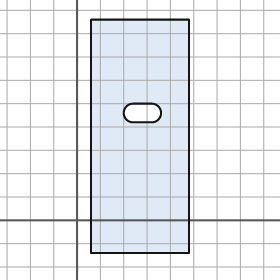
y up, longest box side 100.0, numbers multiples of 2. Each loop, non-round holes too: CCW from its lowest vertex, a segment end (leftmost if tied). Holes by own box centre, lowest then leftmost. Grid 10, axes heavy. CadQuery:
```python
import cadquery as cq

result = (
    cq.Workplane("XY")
    .moveTo(6.0, -14.0)
    .lineTo(48.0, -14.0)
    .lineTo(48.0, 86.0)
    .lineTo(6.0, 86.0)
    .close()
    .moveTo(24.0, 42.0)
    .lineTo(32.0, 42.0)
    .threePointArc((36.0, 46.0), (32.0, 50.0))
    .lineTo(24.0, 50.0)
    .threePointArc((20.0, 46.0), (24.0, 42.0))
    .close()
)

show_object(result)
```